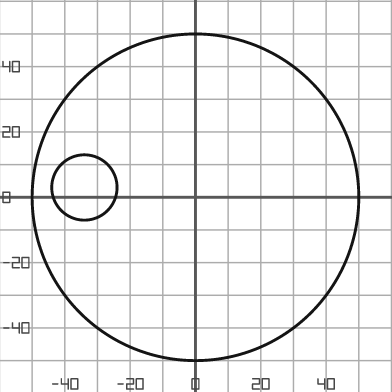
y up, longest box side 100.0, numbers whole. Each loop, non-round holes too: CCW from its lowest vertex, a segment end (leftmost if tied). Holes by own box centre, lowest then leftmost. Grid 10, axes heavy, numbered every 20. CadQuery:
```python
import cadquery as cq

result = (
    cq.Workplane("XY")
    .moveTo(0.0, 0.0)
    .circle(50.0)
    .moveTo(-34.0, 3.0)
    .circle(10.0)
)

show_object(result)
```